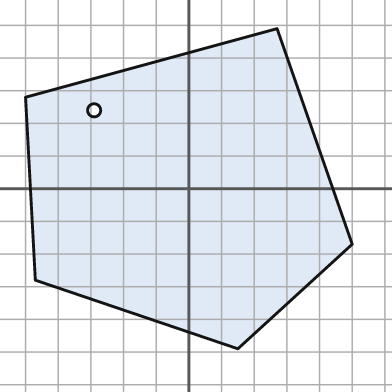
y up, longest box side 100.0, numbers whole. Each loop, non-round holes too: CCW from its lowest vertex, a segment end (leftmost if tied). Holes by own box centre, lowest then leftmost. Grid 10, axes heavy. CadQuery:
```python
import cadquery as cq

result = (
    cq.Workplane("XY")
    .moveTo(15.0, -49.0)
    .lineTo(50.0, -17.0)
    .lineTo(27.0, 49.0)
    .lineTo(-50.0, 28.0)
    .lineTo(-47.0, -28.0)
    .close()
    .moveTo(-29.0, 24.0)
    .circle(2.0)
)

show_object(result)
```